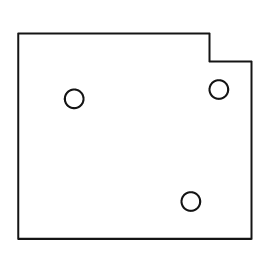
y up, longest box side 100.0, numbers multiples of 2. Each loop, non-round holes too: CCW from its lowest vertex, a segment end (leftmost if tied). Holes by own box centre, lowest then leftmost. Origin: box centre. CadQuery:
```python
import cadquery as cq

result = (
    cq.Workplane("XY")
    .moveTo(-50.0, -44.0)
    .lineTo(50.0, -44.0)
    .lineTo(50.0, 32.0)
    .lineTo(32.0, 32.0)
    .lineTo(32.0, 44.0)
    .lineTo(-50.0, 44.0)
    .close()
    .moveTo(24.0, -28.0)
    .circle(4.0)
    .moveTo(-26.0, 16.0)
    .circle(4.0)
    .moveTo(36.0, 20.0)
    .circle(4.0)
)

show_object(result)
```